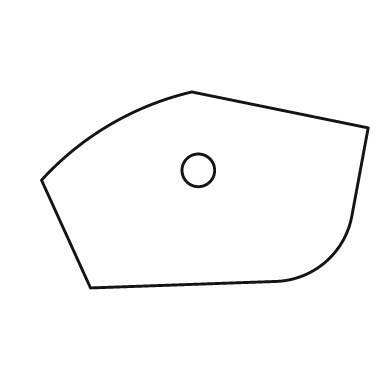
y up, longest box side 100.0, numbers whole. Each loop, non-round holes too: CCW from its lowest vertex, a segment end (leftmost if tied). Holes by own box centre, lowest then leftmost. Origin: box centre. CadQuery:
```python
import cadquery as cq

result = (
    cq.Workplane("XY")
    .moveTo(-35.0, -30.0)
    .lineTo(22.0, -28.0)
    .threePointArc((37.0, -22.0), (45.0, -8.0))
    .lineTo(50.0, 19.0)
    .lineTo(-4.0, 30.0)
    .threePointArc((-29.0, 20.0), (-50.0, 3.0))
    .close()
    .moveTo(-2.0, 6.0)
    .circle(5.0)
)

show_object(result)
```